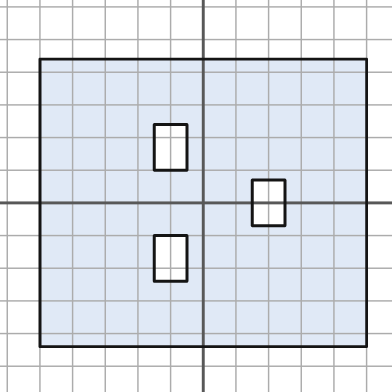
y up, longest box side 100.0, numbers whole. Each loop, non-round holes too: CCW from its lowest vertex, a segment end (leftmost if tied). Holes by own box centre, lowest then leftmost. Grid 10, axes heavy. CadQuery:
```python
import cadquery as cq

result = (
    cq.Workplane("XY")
    .moveTo(-50.0, -44.0)
    .lineTo(50.0, -44.0)
    .lineTo(50.0, 44.0)
    .lineTo(-50.0, 44.0)
    .close()
    .moveTo(-15.0, -24.0)
    .lineTo(-5.0, -24.0)
    .lineTo(-5.0, -10.0)
    .lineTo(-15.0, -10.0)
    .close()
    .moveTo(15.0, -7.0)
    .lineTo(25.0, -7.0)
    .lineTo(25.0, 7.0)
    .lineTo(15.0, 7.0)
    .close()
    .moveTo(-15.0, 10.0)
    .lineTo(-5.0, 10.0)
    .lineTo(-5.0, 24.0)
    .lineTo(-15.0, 24.0)
    .close()
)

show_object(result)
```